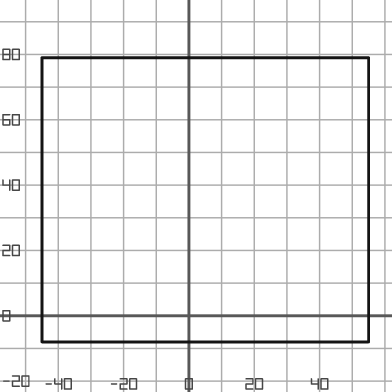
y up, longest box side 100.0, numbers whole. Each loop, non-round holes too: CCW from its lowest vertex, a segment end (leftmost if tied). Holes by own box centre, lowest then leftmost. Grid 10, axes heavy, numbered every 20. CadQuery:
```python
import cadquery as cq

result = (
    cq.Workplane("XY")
    .moveTo(-45.0, -8.0)
    .lineTo(55.0, -8.0)
    .lineTo(55.0, 79.0)
    .lineTo(-45.0, 79.0)
    .close()
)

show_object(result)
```